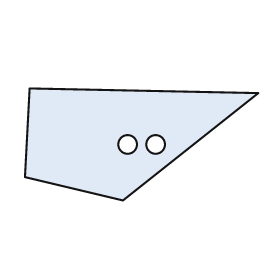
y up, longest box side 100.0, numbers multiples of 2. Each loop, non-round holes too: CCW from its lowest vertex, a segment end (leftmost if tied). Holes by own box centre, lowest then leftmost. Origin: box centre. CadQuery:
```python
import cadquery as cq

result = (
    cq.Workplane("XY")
    .moveTo(-8.0, -24.0)
    .lineTo(50.0, 22.0)
    .lineTo(-48.0, 24.0)
    .lineTo(-50.0, -14.0)
    .close()
    .moveTo(-6.0, 0.0)
    .circle(4.0)
    .moveTo(6.0, 0.0)
    .circle(4.0)
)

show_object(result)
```